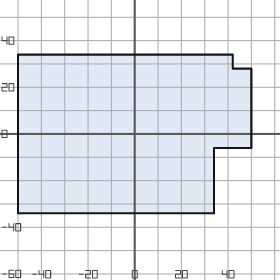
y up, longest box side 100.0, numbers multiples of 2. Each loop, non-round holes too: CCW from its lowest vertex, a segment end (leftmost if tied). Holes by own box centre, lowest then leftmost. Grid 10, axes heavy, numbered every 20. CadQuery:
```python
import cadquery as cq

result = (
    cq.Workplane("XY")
    .moveTo(-50.0, -34.0)
    .lineTo(34.0, -34.0)
    .lineTo(34.0, -6.0)
    .lineTo(50.0, -6.0)
    .lineTo(50.0, 28.0)
    .lineTo(42.0, 28.0)
    .lineTo(42.0, 34.0)
    .lineTo(-50.0, 34.0)
    .close()
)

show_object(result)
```